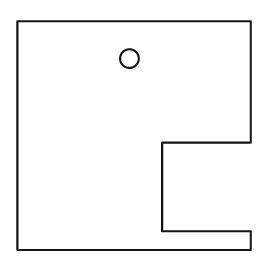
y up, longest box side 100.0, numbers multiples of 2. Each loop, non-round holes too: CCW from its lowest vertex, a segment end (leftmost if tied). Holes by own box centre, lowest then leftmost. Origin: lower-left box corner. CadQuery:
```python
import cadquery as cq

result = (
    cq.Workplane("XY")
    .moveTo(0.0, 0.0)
    .lineTo(100.0, 0.0)
    .lineTo(100.0, 8.0)
    .lineTo(62.0, 8.0)
    .lineTo(62.0, 46.0)
    .lineTo(100.0, 46.0)
    .lineTo(100.0, 98.0)
    .lineTo(0.0, 98.0)
    .close()
    .moveTo(48.0, 82.0)
    .circle(4.0)
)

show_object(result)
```